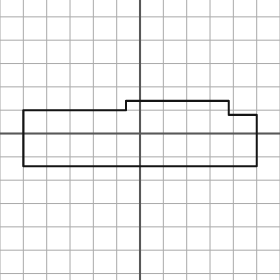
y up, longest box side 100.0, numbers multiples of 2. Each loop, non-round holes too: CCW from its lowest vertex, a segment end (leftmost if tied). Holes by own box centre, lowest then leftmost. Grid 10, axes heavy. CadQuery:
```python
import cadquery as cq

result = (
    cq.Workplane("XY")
    .moveTo(-50.0, -14.0)
    .lineTo(50.0, -14.0)
    .lineTo(50.0, 8.0)
    .lineTo(38.0, 8.0)
    .lineTo(38.0, 14.0)
    .lineTo(-6.0, 14.0)
    .lineTo(-6.0, 10.0)
    .lineTo(-50.0, 10.0)
    .close()
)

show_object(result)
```